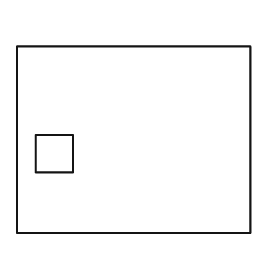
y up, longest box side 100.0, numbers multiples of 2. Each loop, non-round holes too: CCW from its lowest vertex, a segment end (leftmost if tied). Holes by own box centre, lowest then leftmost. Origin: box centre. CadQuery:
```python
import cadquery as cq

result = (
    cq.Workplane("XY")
    .moveTo(-50.0, -40.0)
    .lineTo(50.0, -40.0)
    .lineTo(50.0, 40.0)
    .lineTo(-50.0, 40.0)
    .close()
    .moveTo(-42.0, -14.0)
    .lineTo(-26.0, -14.0)
    .lineTo(-26.0, 2.0)
    .lineTo(-42.0, 2.0)
    .close()
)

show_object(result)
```